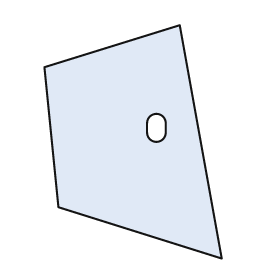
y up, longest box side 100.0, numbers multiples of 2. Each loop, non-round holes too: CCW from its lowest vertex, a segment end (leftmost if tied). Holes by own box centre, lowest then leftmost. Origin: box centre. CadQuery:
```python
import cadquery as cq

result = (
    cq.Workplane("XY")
    .moveTo(38.0, -50.0)
    .lineTo(20.0, 50.0)
    .lineTo(-38.0, 32.0)
    .lineTo(-32.0, -28.0)
    .close()
    .moveTo(6.0, 4.0)
    .threePointArc((10.0, 0.0), (14.0, 4.0))
    .lineTo(14.0, 8.0)
    .threePointArc((10.0, 12.0), (6.0, 8.0))
    .close()
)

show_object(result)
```